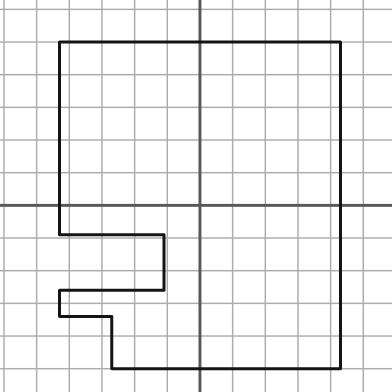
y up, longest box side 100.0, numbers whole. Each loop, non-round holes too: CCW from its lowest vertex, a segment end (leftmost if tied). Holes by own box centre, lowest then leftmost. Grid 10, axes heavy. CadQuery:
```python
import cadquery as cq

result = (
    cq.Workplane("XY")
    .moveTo(-27.0, -50.0)
    .lineTo(43.0, -50.0)
    .lineTo(43.0, 50.0)
    .lineTo(-43.0, 50.0)
    .lineTo(-43.0, -9.0)
    .lineTo(-11.0, -9.0)
    .lineTo(-11.0, -26.0)
    .lineTo(-43.0, -26.0)
    .lineTo(-43.0, -34.0)
    .lineTo(-27.0, -34.0)
    .close()
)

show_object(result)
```